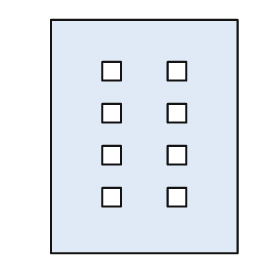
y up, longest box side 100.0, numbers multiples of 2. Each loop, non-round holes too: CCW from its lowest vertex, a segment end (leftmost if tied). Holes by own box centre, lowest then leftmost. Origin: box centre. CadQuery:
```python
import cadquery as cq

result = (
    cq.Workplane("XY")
    .moveTo(-40.0, -50.0)
    .lineTo(40.0, -50.0)
    .lineTo(40.0, 50.0)
    .lineTo(-40.0, 50.0)
    .close()
    .moveTo(-18.0, -30.0)
    .lineTo(-10.0, -30.0)
    .lineTo(-10.0, -22.0)
    .lineTo(-18.0, -22.0)
    .close()
    .moveTo(10.0, -30.0)
    .lineTo(18.0, -30.0)
    .lineTo(18.0, -22.0)
    .lineTo(10.0, -22.0)
    .close()
    .moveTo(-18.0, -12.0)
    .lineTo(-10.0, -12.0)
    .lineTo(-10.0, -4.0)
    .lineTo(-18.0, -4.0)
    .close()
    .moveTo(10.0, -12.0)
    .lineTo(18.0, -12.0)
    .lineTo(18.0, -4.0)
    .lineTo(10.0, -4.0)
    .close()
    .moveTo(-18.0, 6.0)
    .lineTo(-10.0, 6.0)
    .lineTo(-10.0, 14.0)
    .lineTo(-18.0, 14.0)
    .close()
    .moveTo(10.0, 6.0)
    .lineTo(18.0, 6.0)
    .lineTo(18.0, 14.0)
    .lineTo(10.0, 14.0)
    .close()
    .moveTo(-18.0, 24.0)
    .lineTo(-10.0, 24.0)
    .lineTo(-10.0, 32.0)
    .lineTo(-18.0, 32.0)
    .close()
    .moveTo(10.0, 24.0)
    .lineTo(18.0, 24.0)
    .lineTo(18.0, 32.0)
    .lineTo(10.0, 32.0)
    .close()
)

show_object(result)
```